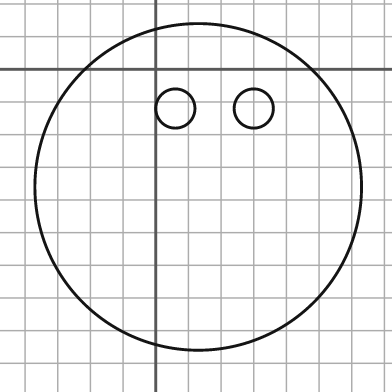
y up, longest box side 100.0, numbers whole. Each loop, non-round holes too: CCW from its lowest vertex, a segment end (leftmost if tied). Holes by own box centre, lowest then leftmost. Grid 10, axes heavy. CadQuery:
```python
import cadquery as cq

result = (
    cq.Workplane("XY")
    .moveTo(13.0, -36.0)
    .circle(50.0)
    .moveTo(6.0, -12.0)
    .circle(6.0)
    .moveTo(30.0, -12.0)
    .circle(6.0)
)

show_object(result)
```